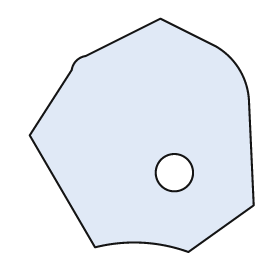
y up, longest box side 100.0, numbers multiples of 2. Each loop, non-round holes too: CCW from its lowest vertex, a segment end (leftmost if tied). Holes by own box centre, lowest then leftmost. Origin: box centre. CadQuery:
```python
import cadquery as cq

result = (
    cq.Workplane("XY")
    .moveTo(20.0, -50.0)
    .lineTo(48.0, -30.0)
    .lineTo(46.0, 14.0)
    .threePointArc((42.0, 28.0), (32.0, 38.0))
    .lineTo(8.0, 50.0)
    .lineTo(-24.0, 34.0)
    .threePointArc((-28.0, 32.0), (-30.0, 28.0))
    .lineTo(-48.0, 0.0)
    .lineTo(-20.0, -48.0)
    .threePointArc((0.0, -46.0), (20.0, -50.0))
    .close()
    .moveTo(14.0, -16.0)
    .circle(8.0)
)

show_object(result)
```